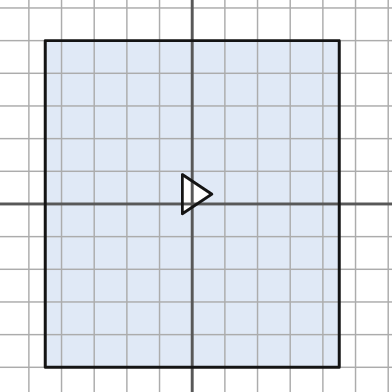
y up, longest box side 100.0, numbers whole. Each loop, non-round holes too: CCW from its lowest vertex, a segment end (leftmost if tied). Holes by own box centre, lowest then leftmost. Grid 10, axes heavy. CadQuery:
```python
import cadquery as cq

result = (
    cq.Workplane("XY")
    .moveTo(-45.0, -50.0)
    .lineTo(45.0, -50.0)
    .lineTo(45.0, 50.0)
    .lineTo(-45.0, 50.0)
    .close()
    .moveTo(-3.0, -3.0)
    .lineTo(6.0, 3.0)
    .lineTo(-3.0, 9.0)
    .close()
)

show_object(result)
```